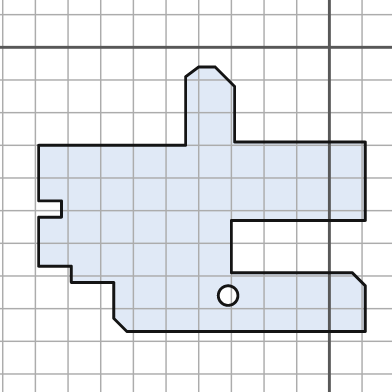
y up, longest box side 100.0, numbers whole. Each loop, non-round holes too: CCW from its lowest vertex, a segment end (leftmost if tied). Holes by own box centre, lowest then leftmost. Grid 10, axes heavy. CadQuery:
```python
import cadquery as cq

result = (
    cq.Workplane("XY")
    .moveTo(-62.0, -87.0)
    .lineTo(11.0, -87.0)
    .lineTo(11.0, -73.0)
    .lineTo(7.0, -69.0)
    .lineTo(-30.0, -69.0)
    .lineTo(-30.0, -53.0)
    .lineTo(11.0, -53.0)
    .lineTo(11.0, -29.0)
    .lineTo(-29.0, -29.0)
    .lineTo(-29.0, -12.0)
    .lineTo(-35.0, -6.0)
    .lineTo(-40.0, -6.0)
    .lineTo(-44.0, -9.0)
    .lineTo(-44.0, -30.0)
    .lineTo(-89.0, -30.0)
    .lineTo(-89.0, -47.0)
    .lineTo(-82.0, -47.0)
    .lineTo(-82.0, -52.0)
    .lineTo(-89.0, -52.0)
    .lineTo(-89.0, -67.0)
    .lineTo(-79.0, -67.0)
    .lineTo(-79.0, -72.0)
    .lineTo(-66.0, -72.0)
    .lineTo(-66.0, -83.0)
    .close()
    .moveTo(-31.0, -76.0)
    .circle(3.0)
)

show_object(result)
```